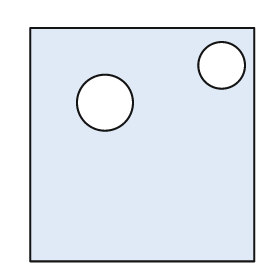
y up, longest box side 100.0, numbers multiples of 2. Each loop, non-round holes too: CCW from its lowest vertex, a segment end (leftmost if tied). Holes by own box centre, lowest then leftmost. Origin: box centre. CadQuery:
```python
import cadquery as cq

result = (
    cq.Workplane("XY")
    .moveTo(-48.0, -50.0)
    .lineTo(48.0, -50.0)
    .lineTo(48.0, 50.0)
    .lineTo(-48.0, 50.0)
    .close()
    .moveTo(-16.0, 18.0)
    .circle(12.0)
    .moveTo(34.0, 34.0)
    .circle(10.0)
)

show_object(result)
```